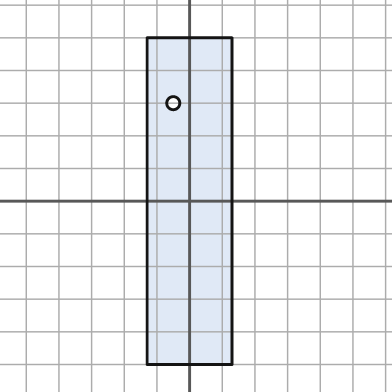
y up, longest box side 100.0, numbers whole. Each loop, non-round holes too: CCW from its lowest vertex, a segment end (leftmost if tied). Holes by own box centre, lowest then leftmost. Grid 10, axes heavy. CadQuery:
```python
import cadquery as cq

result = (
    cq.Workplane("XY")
    .moveTo(-13.0, -50.0)
    .lineTo(13.0, -50.0)
    .lineTo(13.0, 50.0)
    .lineTo(-13.0, 50.0)
    .close()
    .moveTo(-5.0, 30.0)
    .circle(2.0)
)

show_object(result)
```